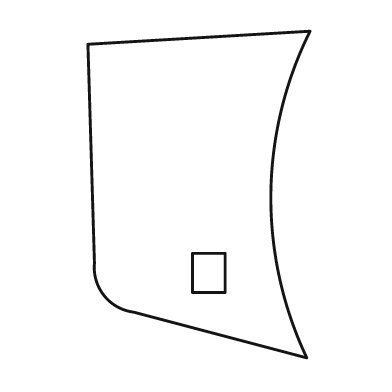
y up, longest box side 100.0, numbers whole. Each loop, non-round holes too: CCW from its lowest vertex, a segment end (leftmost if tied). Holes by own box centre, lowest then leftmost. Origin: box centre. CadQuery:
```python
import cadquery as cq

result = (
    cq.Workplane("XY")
    .moveTo(33.0, -50.0)
    .threePointArc((22.0, 0.0), (34.0, 50.0))
    .lineTo(-34.0, 46.0)
    .lineTo(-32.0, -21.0)
    .threePointArc((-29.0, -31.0), (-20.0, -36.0))
    .close()
    .moveTo(-2.0, -30.0)
    .lineTo(8.0, -30.0)
    .lineTo(8.0, -18.0)
    .lineTo(-2.0, -18.0)
    .close()
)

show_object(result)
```